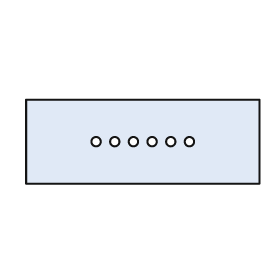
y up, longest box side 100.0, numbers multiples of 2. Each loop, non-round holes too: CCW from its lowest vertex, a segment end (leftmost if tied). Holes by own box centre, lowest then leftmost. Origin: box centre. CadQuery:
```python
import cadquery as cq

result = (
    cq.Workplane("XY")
    .moveTo(-50.0, -18.0)
    .lineTo(50.0, -18.0)
    .lineTo(50.0, 18.0)
    .lineTo(-50.0, 18.0)
    .close()
    .moveTo(-20.0, 0.0)
    .circle(2.0)
    .moveTo(-12.0, 0.0)
    .circle(2.0)
    .moveTo(-4.0, 0.0)
    .circle(2.0)
    .moveTo(4.0, 0.0)
    .circle(2.0)
    .moveTo(12.0, 0.0)
    .circle(2.0)
    .moveTo(20.0, 0.0)
    .circle(2.0)
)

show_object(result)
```